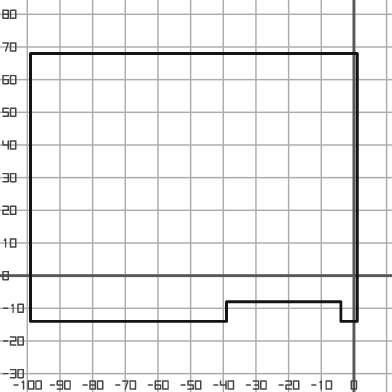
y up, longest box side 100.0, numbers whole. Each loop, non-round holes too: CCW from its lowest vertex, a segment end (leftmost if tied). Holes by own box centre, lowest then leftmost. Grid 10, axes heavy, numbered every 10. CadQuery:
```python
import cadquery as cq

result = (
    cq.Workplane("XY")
    .moveTo(-99.0, -14.0)
    .lineTo(-39.0, -14.0)
    .lineTo(-39.0, -8.0)
    .lineTo(-4.0, -8.0)
    .lineTo(-4.0, -14.0)
    .lineTo(1.0, -14.0)
    .lineTo(1.0, 68.0)
    .lineTo(-99.0, 68.0)
    .close()
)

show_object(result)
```